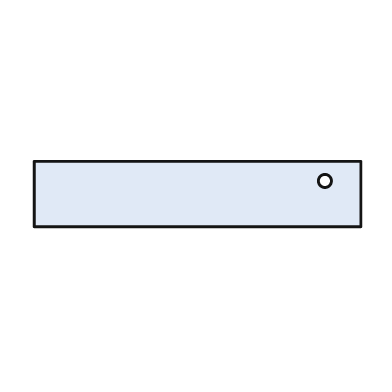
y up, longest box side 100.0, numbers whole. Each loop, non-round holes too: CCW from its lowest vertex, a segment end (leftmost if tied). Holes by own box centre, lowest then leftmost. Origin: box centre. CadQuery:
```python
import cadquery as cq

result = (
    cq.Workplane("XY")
    .moveTo(-50.0, -10.0)
    .lineTo(50.0, -10.0)
    .lineTo(50.0, 10.0)
    .lineTo(-50.0, 10.0)
    .close()
    .moveTo(39.0, 4.0)
    .circle(2.0)
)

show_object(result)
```